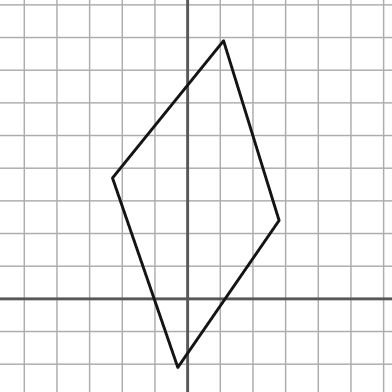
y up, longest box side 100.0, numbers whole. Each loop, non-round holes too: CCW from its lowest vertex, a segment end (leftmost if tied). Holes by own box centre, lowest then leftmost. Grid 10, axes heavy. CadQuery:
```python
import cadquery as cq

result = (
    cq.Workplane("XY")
    .moveTo(-3.0, -21.0)
    .lineTo(28.0, 24.0)
    .lineTo(11.0, 79.0)
    .lineTo(-23.0, 37.0)
    .close()
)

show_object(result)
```